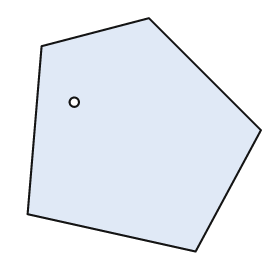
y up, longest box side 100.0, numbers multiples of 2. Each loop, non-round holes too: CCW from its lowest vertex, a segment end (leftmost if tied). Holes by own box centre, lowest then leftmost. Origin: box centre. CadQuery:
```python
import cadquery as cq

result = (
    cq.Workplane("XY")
    .moveTo(22.0, -50.0)
    .lineTo(50.0, 2.0)
    .lineTo(2.0, 50.0)
    .lineTo(-44.0, 38.0)
    .lineTo(-50.0, -34.0)
    .close()
    .moveTo(-30.0, 14.0)
    .circle(2.0)
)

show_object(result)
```